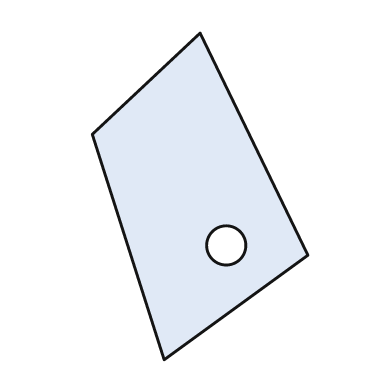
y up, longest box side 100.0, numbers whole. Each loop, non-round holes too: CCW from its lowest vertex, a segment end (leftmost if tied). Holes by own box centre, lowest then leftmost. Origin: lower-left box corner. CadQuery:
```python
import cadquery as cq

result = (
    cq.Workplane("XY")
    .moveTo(22.0, 0.0)
    .lineTo(66.0, 32.0)
    .lineTo(33.0, 100.0)
    .lineTo(0.0, 69.0)
    .close()
    .moveTo(41.0, 35.0)
    .circle(6.0)
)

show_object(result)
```